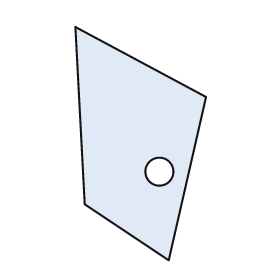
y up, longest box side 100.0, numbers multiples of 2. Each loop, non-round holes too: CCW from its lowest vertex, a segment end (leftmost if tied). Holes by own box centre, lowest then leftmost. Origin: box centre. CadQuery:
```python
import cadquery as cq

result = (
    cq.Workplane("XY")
    .moveTo(12.0, -50.0)
    .lineTo(28.0, 20.0)
    .lineTo(-28.0, 50.0)
    .lineTo(-24.0, -26.0)
    .close()
    .moveTo(8.0, -12.0)
    .circle(6.0)
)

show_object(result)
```